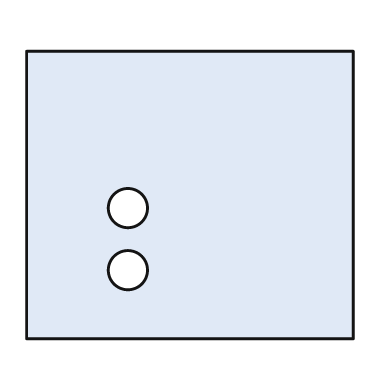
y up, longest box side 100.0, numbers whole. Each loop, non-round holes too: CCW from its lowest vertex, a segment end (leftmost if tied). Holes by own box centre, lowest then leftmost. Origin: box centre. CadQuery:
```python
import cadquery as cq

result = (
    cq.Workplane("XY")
    .moveTo(-50.0, -44.0)
    .lineTo(50.0, -44.0)
    .lineTo(50.0, 44.0)
    .lineTo(-50.0, 44.0)
    .close()
    .moveTo(-19.0, -23.0)
    .circle(6.0)
    .moveTo(-19.0, -4.0)
    .circle(6.0)
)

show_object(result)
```